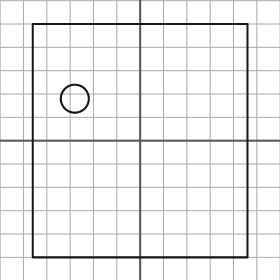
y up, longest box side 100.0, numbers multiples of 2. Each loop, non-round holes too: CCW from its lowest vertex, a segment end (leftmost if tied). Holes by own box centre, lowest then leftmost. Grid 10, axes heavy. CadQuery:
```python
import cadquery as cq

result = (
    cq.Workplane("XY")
    .moveTo(-46.0, -50.0)
    .lineTo(46.0, -50.0)
    .lineTo(46.0, 50.0)
    .lineTo(-46.0, 50.0)
    .close()
    .moveTo(-28.0, 18.0)
    .circle(6.0)
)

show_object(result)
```